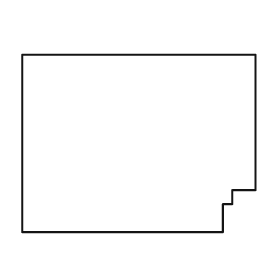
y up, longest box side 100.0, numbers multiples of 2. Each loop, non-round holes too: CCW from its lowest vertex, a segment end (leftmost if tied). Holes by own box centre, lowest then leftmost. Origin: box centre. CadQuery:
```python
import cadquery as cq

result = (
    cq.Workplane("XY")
    .moveTo(-50.0, -38.0)
    .lineTo(36.0, -38.0)
    .lineTo(36.0, -26.0)
    .lineTo(40.0, -26.0)
    .lineTo(40.0, -20.0)
    .lineTo(50.0, -20.0)
    .lineTo(50.0, 38.0)
    .lineTo(-50.0, 38.0)
    .close()
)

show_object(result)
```